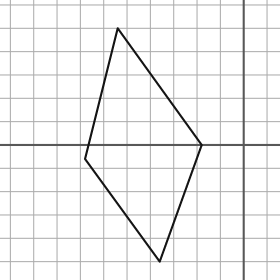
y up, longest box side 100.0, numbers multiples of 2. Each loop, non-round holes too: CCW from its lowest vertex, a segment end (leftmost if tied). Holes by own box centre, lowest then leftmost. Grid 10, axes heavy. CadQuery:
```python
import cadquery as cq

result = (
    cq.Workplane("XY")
    .moveTo(-36.0, -50.0)
    .lineTo(-18.0, 0.0)
    .lineTo(-54.0, 50.0)
    .lineTo(-68.0, -6.0)
    .close()
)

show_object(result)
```